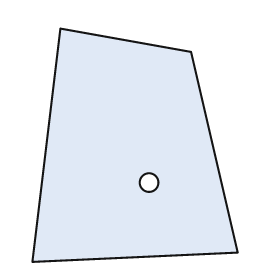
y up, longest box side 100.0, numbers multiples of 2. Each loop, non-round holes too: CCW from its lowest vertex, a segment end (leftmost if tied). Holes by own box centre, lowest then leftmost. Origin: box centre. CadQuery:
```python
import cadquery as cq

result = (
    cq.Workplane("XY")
    .moveTo(-44.0, -50.0)
    .lineTo(44.0, -46.0)
    .lineTo(24.0, 40.0)
    .lineTo(-32.0, 50.0)
    .close()
    .moveTo(6.0, -16.0)
    .circle(4.0)
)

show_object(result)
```